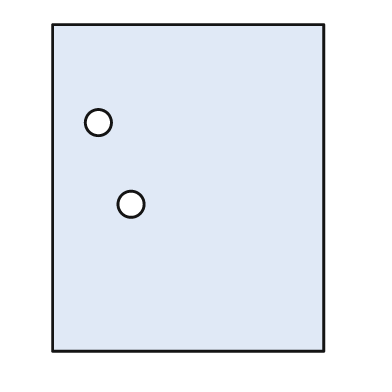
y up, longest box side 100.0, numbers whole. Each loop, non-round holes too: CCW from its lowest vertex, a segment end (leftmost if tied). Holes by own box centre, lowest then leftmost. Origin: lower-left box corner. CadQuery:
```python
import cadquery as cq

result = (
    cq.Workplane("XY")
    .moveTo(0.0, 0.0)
    .lineTo(83.0, 0.0)
    .lineTo(83.0, 100.0)
    .lineTo(0.0, 100.0)
    .close()
    .moveTo(24.0, 45.0)
    .circle(4.0)
    .moveTo(14.0, 70.0)
    .circle(4.0)
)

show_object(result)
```